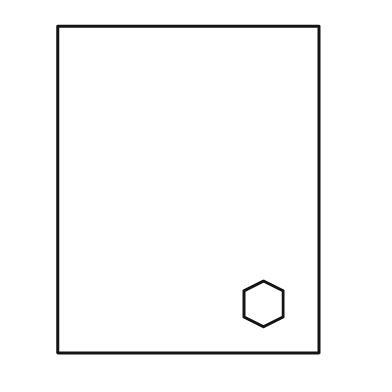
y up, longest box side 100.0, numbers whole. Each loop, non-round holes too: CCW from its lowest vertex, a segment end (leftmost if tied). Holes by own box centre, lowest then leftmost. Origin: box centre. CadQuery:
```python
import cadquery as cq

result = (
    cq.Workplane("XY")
    .moveTo(-40.0, -50.0)
    .lineTo(40.0, -50.0)
    .lineTo(40.0, 50.0)
    .lineTo(-40.0, 50.0)
    .close()
    .moveTo(23.0, -42.0)
    .lineTo(29.0, -39.0)
    .lineTo(29.0, -31.0)
    .lineTo(23.0, -28.0)
    .lineTo(17.0, -31.0)
    .lineTo(17.0, -39.0)
    .close()
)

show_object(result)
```